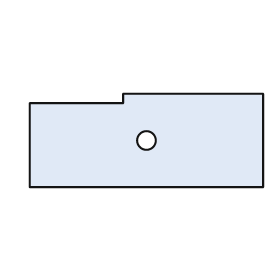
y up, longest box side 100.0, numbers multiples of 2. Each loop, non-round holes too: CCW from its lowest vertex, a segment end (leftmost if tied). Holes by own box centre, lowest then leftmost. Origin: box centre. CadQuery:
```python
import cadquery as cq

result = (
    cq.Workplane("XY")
    .moveTo(-50.0, -20.0)
    .lineTo(50.0, -20.0)
    .lineTo(50.0, 20.0)
    .lineTo(-10.0, 20.0)
    .lineTo(-10.0, 16.0)
    .lineTo(-50.0, 16.0)
    .close()
    .moveTo(0.0, 0.0)
    .circle(4.0)
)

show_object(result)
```